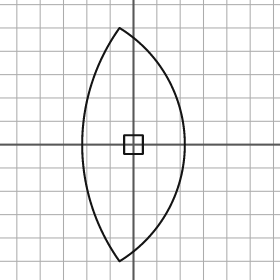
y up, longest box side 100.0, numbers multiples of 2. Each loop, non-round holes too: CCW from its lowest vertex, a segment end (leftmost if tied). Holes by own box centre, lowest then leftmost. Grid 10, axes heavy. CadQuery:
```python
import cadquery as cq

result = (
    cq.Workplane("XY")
    .moveTo(-6.0, -50.0)
    .threePointArc((22.0, 0.0), (-6.0, 50.0))
    .threePointArc((-22.0, 0.0), (-6.0, -50.0))
    .close()
    .moveTo(-4.0, -4.0)
    .lineTo(4.0, -4.0)
    .lineTo(4.0, 4.0)
    .lineTo(-4.0, 4.0)
    .close()
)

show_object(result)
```